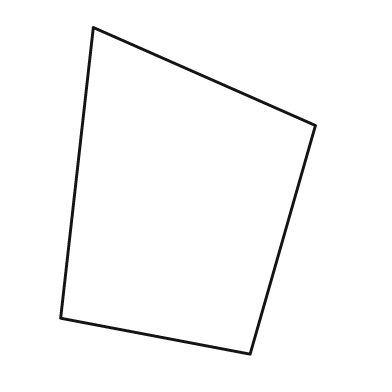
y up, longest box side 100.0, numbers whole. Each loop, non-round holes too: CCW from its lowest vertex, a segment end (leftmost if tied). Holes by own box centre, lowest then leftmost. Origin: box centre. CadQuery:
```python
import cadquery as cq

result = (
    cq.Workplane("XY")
    .moveTo(19.0, -50.0)
    .lineTo(39.0, 20.0)
    .lineTo(-29.0, 50.0)
    .lineTo(-39.0, -39.0)
    .close()
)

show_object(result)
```